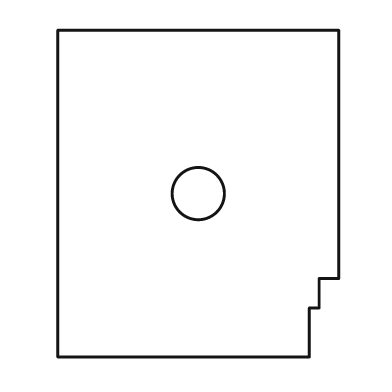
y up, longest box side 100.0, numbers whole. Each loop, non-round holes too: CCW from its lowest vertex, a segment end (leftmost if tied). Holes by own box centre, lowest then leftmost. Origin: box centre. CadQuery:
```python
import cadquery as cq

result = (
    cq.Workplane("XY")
    .moveTo(-43.0, -50.0)
    .lineTo(34.0, -50.0)
    .lineTo(34.0, -35.0)
    .lineTo(37.0, -35.0)
    .lineTo(37.0, -26.0)
    .lineTo(43.0, -26.0)
    .lineTo(43.0, 50.0)
    .lineTo(-43.0, 50.0)
    .close()
    .moveTo(0.0, 0.0)
    .circle(8.0)
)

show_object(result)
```